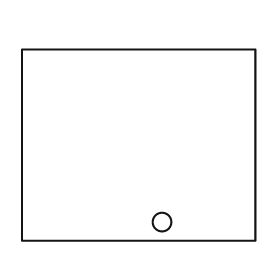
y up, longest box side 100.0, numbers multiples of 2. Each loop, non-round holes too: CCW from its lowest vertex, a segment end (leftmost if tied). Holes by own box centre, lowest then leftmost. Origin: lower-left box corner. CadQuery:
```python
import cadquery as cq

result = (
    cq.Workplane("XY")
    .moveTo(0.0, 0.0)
    .lineTo(100.0, 0.0)
    .lineTo(100.0, 82.0)
    .lineTo(0.0, 82.0)
    .close()
    .moveTo(60.0, 8.0)
    .circle(4.0)
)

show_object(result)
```